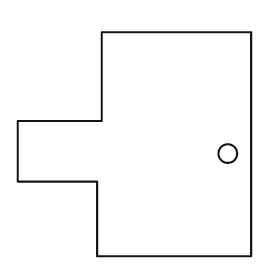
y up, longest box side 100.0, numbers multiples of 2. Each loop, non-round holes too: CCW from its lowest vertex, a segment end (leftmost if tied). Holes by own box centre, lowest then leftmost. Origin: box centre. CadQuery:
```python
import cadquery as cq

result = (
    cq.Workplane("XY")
    .moveTo(-16.0, -48.0)
    .lineTo(50.0, -48.0)
    .lineTo(50.0, 48.0)
    .lineTo(-14.0, 48.0)
    .lineTo(-14.0, 10.0)
    .lineTo(-50.0, 10.0)
    .lineTo(-50.0, -16.0)
    .lineTo(-16.0, -16.0)
    .close()
    .moveTo(40.0, -4.0)
    .circle(4.0)
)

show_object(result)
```